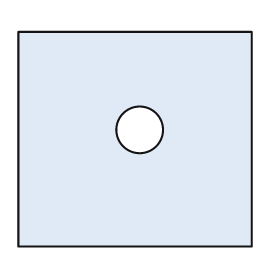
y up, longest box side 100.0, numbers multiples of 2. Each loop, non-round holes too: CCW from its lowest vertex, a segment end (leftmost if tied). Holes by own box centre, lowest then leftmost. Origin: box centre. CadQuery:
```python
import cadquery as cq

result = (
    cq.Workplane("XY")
    .moveTo(-50.0, -46.0)
    .lineTo(50.0, -46.0)
    .lineTo(50.0, 46.0)
    .lineTo(-50.0, 46.0)
    .close()
    .moveTo(2.0, 4.0)
    .circle(10.0)
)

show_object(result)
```